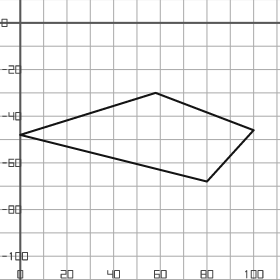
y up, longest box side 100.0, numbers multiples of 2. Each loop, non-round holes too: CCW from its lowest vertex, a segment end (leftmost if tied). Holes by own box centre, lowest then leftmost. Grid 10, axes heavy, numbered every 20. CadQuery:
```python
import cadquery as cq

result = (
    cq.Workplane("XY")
    .moveTo(80.0, -68.0)
    .lineTo(100.0, -46.0)
    .lineTo(58.0, -30.0)
    .lineTo(0.0, -48.0)
    .close()
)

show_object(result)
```